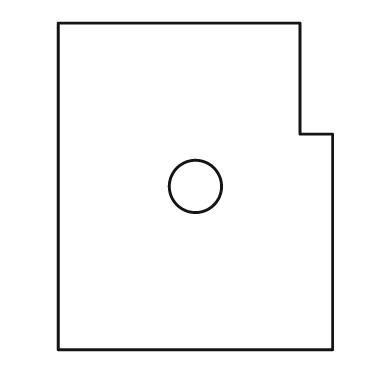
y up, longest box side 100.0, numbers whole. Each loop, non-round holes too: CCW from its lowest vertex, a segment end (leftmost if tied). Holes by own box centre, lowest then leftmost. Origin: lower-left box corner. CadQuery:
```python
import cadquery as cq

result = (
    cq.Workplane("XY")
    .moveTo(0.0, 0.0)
    .lineTo(84.0, 0.0)
    .lineTo(84.0, 66.0)
    .lineTo(74.0, 66.0)
    .lineTo(74.0, 100.0)
    .lineTo(0.0, 100.0)
    .close()
    .moveTo(42.0, 50.0)
    .circle(8.0)
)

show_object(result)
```